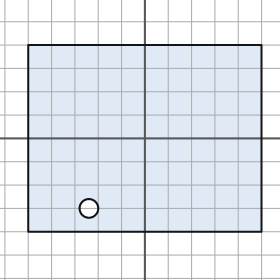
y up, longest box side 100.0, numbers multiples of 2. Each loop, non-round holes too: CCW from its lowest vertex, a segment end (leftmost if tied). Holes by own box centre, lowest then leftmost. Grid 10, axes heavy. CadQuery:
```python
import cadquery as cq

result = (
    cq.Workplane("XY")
    .moveTo(-50.0, -40.0)
    .lineTo(50.0, -40.0)
    .lineTo(50.0, 40.0)
    .lineTo(-50.0, 40.0)
    .close()
    .moveTo(-24.0, -30.0)
    .circle(4.0)
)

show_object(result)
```